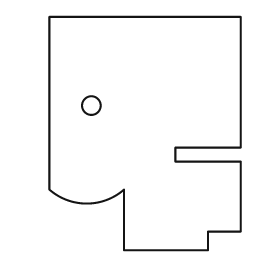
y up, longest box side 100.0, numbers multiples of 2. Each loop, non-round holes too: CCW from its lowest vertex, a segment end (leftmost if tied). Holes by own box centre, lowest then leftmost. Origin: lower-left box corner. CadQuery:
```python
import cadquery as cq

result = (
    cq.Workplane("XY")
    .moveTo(32.0, 0.0)
    .lineTo(68.0, 0.0)
    .lineTo(68.0, 8.0)
    .lineTo(82.0, 8.0)
    .lineTo(82.0, 38.0)
    .lineTo(54.0, 38.0)
    .lineTo(54.0, 44.0)
    .lineTo(82.0, 44.0)
    .lineTo(82.0, 100.0)
    .lineTo(0.0, 100.0)
    .lineTo(0.0, 26.0)
    .threePointArc((16.0, 20.0), (32.0, 26.0))
    .close()
    .moveTo(18.0, 62.0)
    .circle(4.0)
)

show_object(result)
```